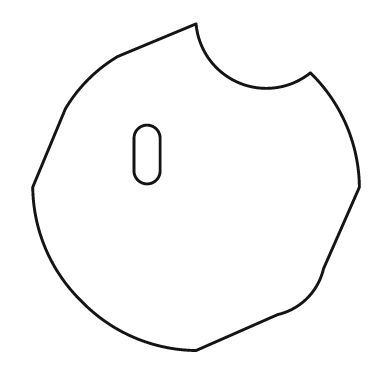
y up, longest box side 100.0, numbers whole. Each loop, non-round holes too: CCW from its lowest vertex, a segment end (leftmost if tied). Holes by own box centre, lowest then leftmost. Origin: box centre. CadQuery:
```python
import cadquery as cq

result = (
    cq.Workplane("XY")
    .moveTo(0.0, -50.0)
    .lineTo(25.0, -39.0)
    .threePointArc((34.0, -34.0), (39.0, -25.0))
    .lineTo(50.0, 0.0)
    .threePointArc((46.0, 19.0), (35.0, 35.0))
    .threePointArc((13.0, 32.0), (0.0, 50.0))
    .lineTo(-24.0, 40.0)
    .threePointArc((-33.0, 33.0), (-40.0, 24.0))
    .lineTo(-50.0, 0.0)
    .threePointArc((-46.0, -19.0), (-35.0, -35.0))
    .threePointArc((-19.0, -46.0), (0.0, -50.0))
    .close()
    .moveTo(-19.0, 5.0)
    .threePointArc((-15.0, 1.0), (-11.0, 5.0))
    .lineTo(-11.0, 15.0)
    .threePointArc((-15.0, 19.0), (-19.0, 15.0))
    .close()
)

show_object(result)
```